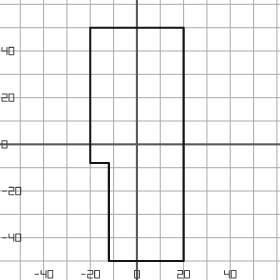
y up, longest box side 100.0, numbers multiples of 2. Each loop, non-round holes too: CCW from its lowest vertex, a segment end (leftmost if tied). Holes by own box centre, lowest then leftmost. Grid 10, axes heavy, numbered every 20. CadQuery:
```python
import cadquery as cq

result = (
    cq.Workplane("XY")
    .moveTo(-12.0, -50.0)
    .lineTo(20.0, -50.0)
    .lineTo(20.0, 50.0)
    .lineTo(-20.0, 50.0)
    .lineTo(-20.0, -8.0)
    .lineTo(-12.0, -8.0)
    .close()
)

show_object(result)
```